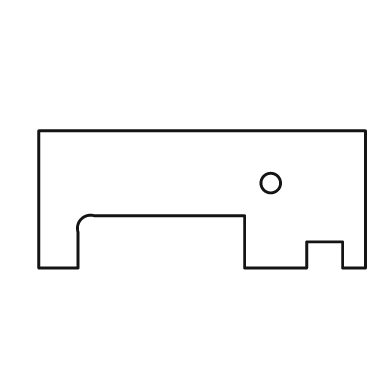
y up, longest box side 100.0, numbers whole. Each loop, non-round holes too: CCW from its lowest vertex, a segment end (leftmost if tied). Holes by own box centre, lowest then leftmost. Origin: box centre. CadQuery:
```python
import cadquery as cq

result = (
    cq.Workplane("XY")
    .moveTo(-50.0, -21.0)
    .lineTo(-38.0, -21.0)
    .lineTo(-38.0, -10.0)
    .threePointArc((-37.0, -6.0), (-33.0, -5.0))
    .lineTo(13.0, -5.0)
    .lineTo(13.0, -21.0)
    .lineTo(32.0, -21.0)
    .lineTo(32.0, -13.0)
    .lineTo(43.0, -13.0)
    .lineTo(43.0, -21.0)
    .lineTo(50.0, -21.0)
    .lineTo(50.0, 21.0)
    .lineTo(-50.0, 21.0)
    .close()
    .moveTo(21.0, 5.0)
    .circle(3.0)
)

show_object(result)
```